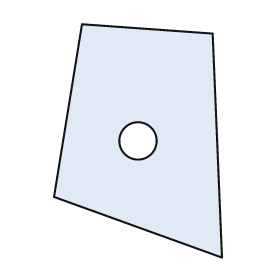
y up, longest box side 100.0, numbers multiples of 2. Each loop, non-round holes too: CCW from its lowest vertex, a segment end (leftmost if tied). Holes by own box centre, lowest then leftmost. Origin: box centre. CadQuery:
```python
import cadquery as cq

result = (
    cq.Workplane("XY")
    .moveTo(36.0, -50.0)
    .lineTo(32.0, 46.0)
    .lineTo(-24.0, 50.0)
    .lineTo(-36.0, -24.0)
    .close()
    .moveTo(0.0, 0.0)
    .circle(8.0)
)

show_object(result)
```